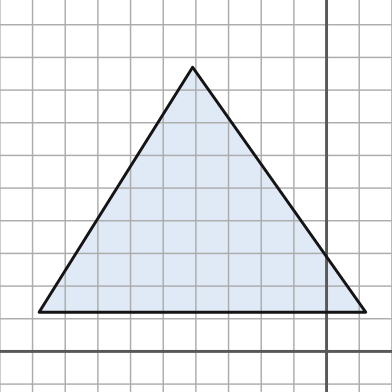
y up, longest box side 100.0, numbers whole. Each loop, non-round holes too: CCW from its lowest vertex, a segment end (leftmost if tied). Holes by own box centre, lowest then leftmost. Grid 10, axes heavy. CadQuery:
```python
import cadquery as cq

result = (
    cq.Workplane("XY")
    .moveTo(-88.0, 12.0)
    .lineTo(12.0, 12.0)
    .lineTo(-41.0, 87.0)
    .close()
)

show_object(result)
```